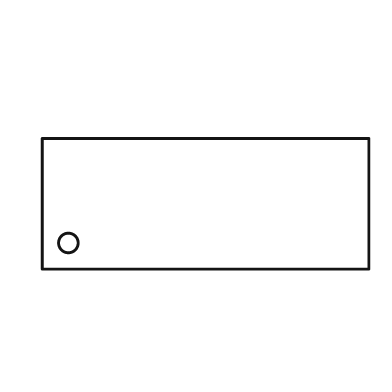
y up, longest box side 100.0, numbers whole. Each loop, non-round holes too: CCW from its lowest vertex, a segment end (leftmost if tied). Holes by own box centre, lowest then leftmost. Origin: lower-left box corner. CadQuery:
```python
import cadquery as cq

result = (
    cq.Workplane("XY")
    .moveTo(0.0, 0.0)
    .lineTo(100.0, 0.0)
    .lineTo(100.0, 40.0)
    .lineTo(0.0, 40.0)
    .close()
    .moveTo(8.0, 8.0)
    .circle(3.0)
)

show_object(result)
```